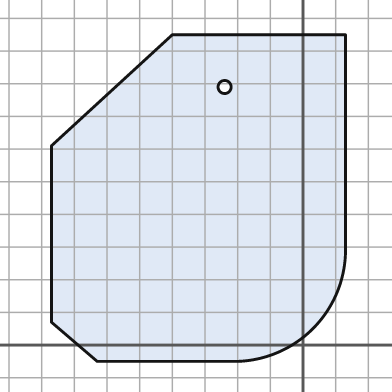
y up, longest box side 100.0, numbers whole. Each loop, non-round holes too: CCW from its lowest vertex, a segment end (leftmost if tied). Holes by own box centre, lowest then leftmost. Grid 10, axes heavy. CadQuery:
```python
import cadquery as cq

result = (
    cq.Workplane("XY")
    .moveTo(-63.0, -5.0)
    .lineTo(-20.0, -5.0)
    .threePointArc((3.0, 5.0), (13.0, 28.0))
    .lineTo(13.0, 95.0)
    .lineTo(-40.0, 95.0)
    .lineTo(-77.0, 61.0)
    .lineTo(-77.0, 7.0)
    .close()
    .moveTo(-24.0, 79.0)
    .circle(2.0)
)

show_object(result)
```